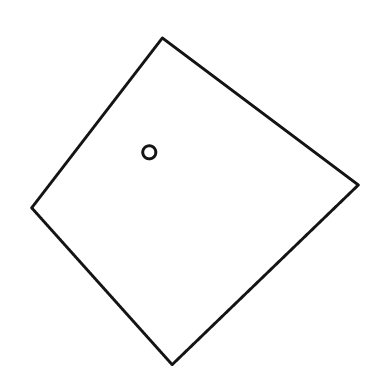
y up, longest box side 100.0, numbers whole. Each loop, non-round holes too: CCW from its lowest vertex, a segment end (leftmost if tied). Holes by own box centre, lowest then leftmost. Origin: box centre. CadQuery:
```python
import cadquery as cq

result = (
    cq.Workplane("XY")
    .moveTo(-7.0, -50.0)
    .lineTo(50.0, 5.0)
    .lineTo(-10.0, 50.0)
    .lineTo(-50.0, -2.0)
    .close()
    .moveTo(-14.0, 15.0)
    .circle(2.0)
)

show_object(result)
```